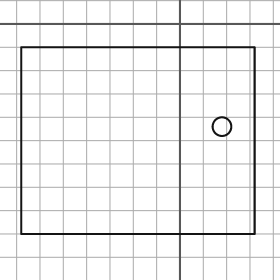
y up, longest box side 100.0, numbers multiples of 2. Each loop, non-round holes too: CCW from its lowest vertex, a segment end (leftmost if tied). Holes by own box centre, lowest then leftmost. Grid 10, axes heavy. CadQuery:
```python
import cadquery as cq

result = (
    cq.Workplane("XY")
    .moveTo(-68.0, -90.0)
    .lineTo(32.0, -90.0)
    .lineTo(32.0, -10.0)
    .lineTo(-68.0, -10.0)
    .close()
    .moveTo(18.0, -44.0)
    .circle(4.0)
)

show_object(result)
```